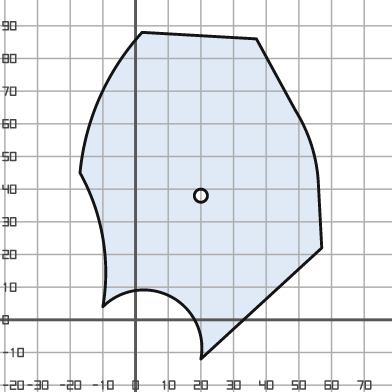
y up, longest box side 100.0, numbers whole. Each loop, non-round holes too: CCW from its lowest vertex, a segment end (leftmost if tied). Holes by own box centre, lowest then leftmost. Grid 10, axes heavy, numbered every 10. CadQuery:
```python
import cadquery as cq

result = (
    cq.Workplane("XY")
    .moveTo(20.0, -12.0)
    .lineTo(57.0, 22.0)
    .lineTo(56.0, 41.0)
    .threePointArc((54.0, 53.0), (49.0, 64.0))
    .lineTo(37.0, 86.0)
    .lineTo(2.0, 88.0)
    .threePointArc((-11.0, 68.0), (-17.0, 45.0))
    .threePointArc((-10.0, 25.0), (-10.0, 4.0))
    .threePointArc((11.0, 7.0), (20.0, -12.0))
    .close()
    .moveTo(20.0, 38.0)
    .circle(2.0)
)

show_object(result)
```